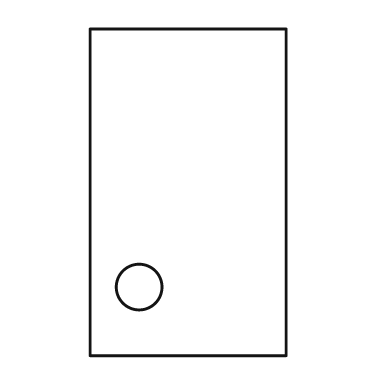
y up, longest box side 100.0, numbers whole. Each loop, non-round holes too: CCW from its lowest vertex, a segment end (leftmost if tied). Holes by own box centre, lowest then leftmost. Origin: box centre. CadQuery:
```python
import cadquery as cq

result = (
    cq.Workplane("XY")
    .moveTo(-30.0, -50.0)
    .lineTo(30.0, -50.0)
    .lineTo(30.0, 50.0)
    .lineTo(-30.0, 50.0)
    .close()
    .moveTo(-15.0, -29.0)
    .circle(7.0)
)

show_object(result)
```